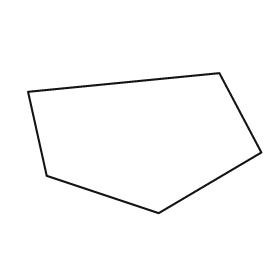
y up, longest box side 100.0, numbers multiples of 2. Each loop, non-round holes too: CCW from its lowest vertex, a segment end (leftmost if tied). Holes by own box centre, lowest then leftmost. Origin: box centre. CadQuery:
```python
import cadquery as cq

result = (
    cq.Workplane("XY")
    .moveTo(6.0, -30.0)
    .lineTo(50.0, -4.0)
    .lineTo(32.0, 30.0)
    .lineTo(-50.0, 22.0)
    .lineTo(-42.0, -14.0)
    .close()
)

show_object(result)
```